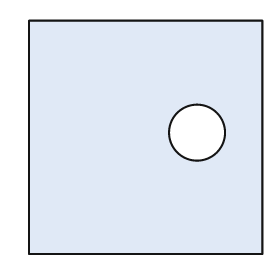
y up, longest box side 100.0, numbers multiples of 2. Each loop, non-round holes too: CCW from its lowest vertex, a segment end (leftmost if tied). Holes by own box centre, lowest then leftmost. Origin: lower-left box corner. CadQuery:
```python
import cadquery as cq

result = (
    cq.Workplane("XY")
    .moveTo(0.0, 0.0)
    .lineTo(100.0, 0.0)
    .lineTo(100.0, 100.0)
    .lineTo(0.0, 100.0)
    .close()
    .moveTo(72.0, 52.0)
    .circle(12.0)
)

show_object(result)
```